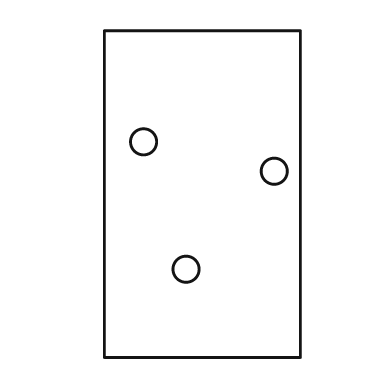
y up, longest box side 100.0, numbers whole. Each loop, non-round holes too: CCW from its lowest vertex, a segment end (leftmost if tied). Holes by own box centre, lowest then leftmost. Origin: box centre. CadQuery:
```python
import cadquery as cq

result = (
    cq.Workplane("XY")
    .moveTo(-30.0, -50.0)
    .lineTo(30.0, -50.0)
    .lineTo(30.0, 50.0)
    .lineTo(-30.0, 50.0)
    .close()
    .moveTo(-5.0, -23.0)
    .circle(4.0)
    .moveTo(22.0, 7.0)
    .circle(4.0)
    .moveTo(-18.0, 16.0)
    .circle(4.0)
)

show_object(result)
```